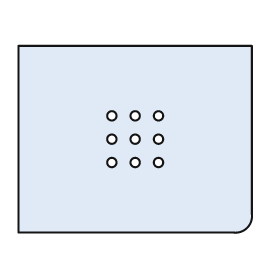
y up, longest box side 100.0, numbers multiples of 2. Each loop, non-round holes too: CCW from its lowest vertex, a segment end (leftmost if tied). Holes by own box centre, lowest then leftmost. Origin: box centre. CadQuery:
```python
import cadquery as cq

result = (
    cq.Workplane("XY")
    .moveTo(-50.0, -40.0)
    .lineTo(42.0, -40.0)
    .threePointArc((48.0, -38.0), (50.0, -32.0))
    .lineTo(50.0, 40.0)
    .lineTo(-50.0, 40.0)
    .close()
    .moveTo(-10.0, -10.0)
    .circle(2.0)
    .moveTo(0.0, -10.0)
    .circle(2.0)
    .moveTo(10.0, -10.0)
    .circle(2.0)
    .moveTo(-10.0, 0.0)
    .circle(2.0)
    .moveTo(0.0, 0.0)
    .circle(2.0)
    .moveTo(10.0, 0.0)
    .circle(2.0)
    .moveTo(-10.0, 10.0)
    .circle(2.0)
    .moveTo(0.0, 10.0)
    .circle(2.0)
    .moveTo(10.0, 10.0)
    .circle(2.0)
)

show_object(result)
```